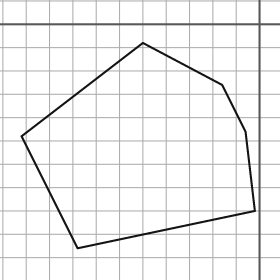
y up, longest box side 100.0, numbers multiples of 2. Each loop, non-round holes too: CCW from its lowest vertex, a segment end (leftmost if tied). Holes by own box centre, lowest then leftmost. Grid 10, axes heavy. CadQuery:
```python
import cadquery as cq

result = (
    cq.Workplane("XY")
    .moveTo(-78.0, -96.0)
    .lineTo(-2.0, -80.0)
    .lineTo(-6.0, -46.0)
    .lineTo(-16.0, -26.0)
    .lineTo(-50.0, -8.0)
    .lineTo(-102.0, -48.0)
    .close()
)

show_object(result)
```